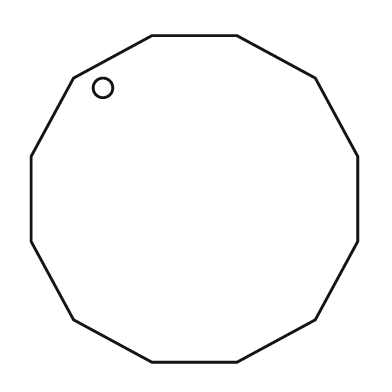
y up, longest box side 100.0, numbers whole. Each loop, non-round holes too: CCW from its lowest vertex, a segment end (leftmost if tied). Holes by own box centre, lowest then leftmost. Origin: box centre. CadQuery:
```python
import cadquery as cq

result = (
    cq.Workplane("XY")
    .moveTo(-13.0, -50.0)
    .lineTo(13.0, -50.0)
    .lineTo(37.0, -37.0)
    .lineTo(50.0, -13.0)
    .lineTo(50.0, 13.0)
    .lineTo(37.0, 37.0)
    .lineTo(13.0, 50.0)
    .lineTo(-13.0, 50.0)
    .lineTo(-37.0, 37.0)
    .lineTo(-50.0, 13.0)
    .lineTo(-50.0, -13.0)
    .lineTo(-37.0, -37.0)
    .close()
    .moveTo(-28.0, 34.0)
    .circle(3.0)
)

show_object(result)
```